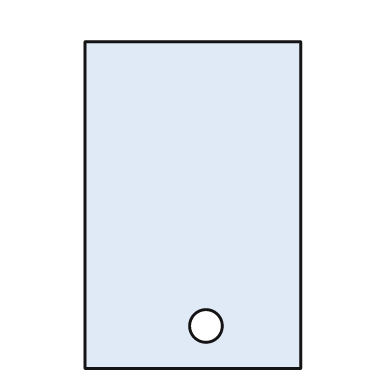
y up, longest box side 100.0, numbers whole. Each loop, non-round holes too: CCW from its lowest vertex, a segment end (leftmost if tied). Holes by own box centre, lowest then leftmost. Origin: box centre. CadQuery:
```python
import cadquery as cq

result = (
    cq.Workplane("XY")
    .moveTo(-33.0, -50.0)
    .lineTo(33.0, -50.0)
    .lineTo(33.0, 50.0)
    .lineTo(-33.0, 50.0)
    .close()
    .moveTo(4.0, -37.0)
    .circle(5.0)
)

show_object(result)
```